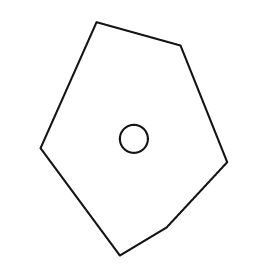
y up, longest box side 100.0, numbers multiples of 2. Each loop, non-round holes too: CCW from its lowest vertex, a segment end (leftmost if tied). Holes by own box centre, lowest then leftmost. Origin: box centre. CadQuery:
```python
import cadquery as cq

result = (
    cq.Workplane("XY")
    .moveTo(-6.0, -50.0)
    .lineTo(14.0, -38.0)
    .lineTo(40.0, -10.0)
    .lineTo(20.0, 40.0)
    .lineTo(-16.0, 50.0)
    .lineTo(-40.0, -4.0)
    .close()
    .moveTo(0.0, 0.0)
    .circle(6.0)
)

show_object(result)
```